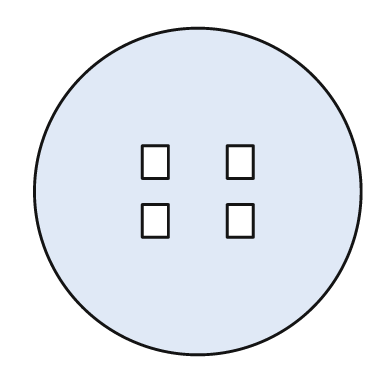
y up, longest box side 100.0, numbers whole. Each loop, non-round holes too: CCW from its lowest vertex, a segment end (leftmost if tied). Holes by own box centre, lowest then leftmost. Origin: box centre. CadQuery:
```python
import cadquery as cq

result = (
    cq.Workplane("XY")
    .moveTo(0.0, 0.0)
    .circle(50.0)
    .moveTo(-17.0, -14.0)
    .lineTo(-9.0, -14.0)
    .lineTo(-9.0, -4.0)
    .lineTo(-17.0, -4.0)
    .close()
    .moveTo(9.0, -14.0)
    .lineTo(17.0, -14.0)
    .lineTo(17.0, -4.0)
    .lineTo(9.0, -4.0)
    .close()
    .moveTo(-17.0, 4.0)
    .lineTo(-9.0, 4.0)
    .lineTo(-9.0, 14.0)
    .lineTo(-17.0, 14.0)
    .close()
    .moveTo(9.0, 4.0)
    .lineTo(17.0, 4.0)
    .lineTo(17.0, 14.0)
    .lineTo(9.0, 14.0)
    .close()
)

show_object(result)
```